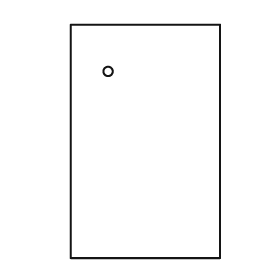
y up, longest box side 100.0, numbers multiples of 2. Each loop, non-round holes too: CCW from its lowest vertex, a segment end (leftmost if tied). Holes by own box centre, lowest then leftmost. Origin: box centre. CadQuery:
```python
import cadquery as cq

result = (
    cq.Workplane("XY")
    .moveTo(-32.0, -50.0)
    .lineTo(32.0, -50.0)
    .lineTo(32.0, 50.0)
    .lineTo(-32.0, 50.0)
    .close()
    .moveTo(-16.0, 30.0)
    .circle(2.0)
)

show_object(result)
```